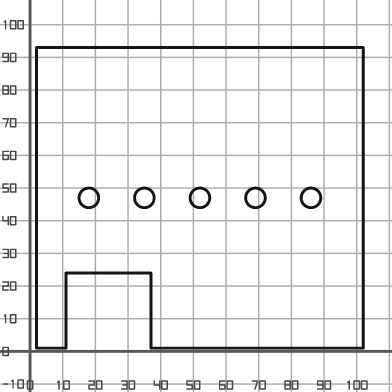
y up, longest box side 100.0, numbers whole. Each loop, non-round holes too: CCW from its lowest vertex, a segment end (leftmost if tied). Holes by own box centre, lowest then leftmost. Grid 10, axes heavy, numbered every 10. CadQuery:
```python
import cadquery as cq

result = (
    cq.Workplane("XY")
    .moveTo(2.0, 1.0)
    .lineTo(11.0, 1.0)
    .lineTo(11.0, 24.0)
    .lineTo(37.0, 24.0)
    .lineTo(37.0, 1.0)
    .lineTo(102.0, 1.0)
    .lineTo(102.0, 93.0)
    .lineTo(2.0, 93.0)
    .close()
    .moveTo(18.0, 47.0)
    .circle(3.0)
    .moveTo(35.0, 47.0)
    .circle(3.0)
    .moveTo(52.0, 47.0)
    .circle(3.0)
    .moveTo(69.0, 47.0)
    .circle(3.0)
    .moveTo(86.0, 47.0)
    .circle(3.0)
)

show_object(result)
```